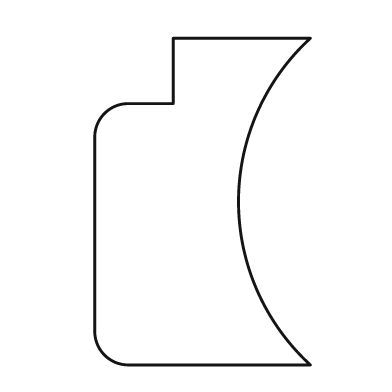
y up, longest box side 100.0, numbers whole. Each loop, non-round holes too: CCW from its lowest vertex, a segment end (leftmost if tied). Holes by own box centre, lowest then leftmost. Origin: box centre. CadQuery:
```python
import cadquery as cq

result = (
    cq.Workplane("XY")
    .moveTo(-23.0, -50.0)
    .lineTo(33.0, -50.0)
    .threePointArc((11.0, 0.0), (33.0, 50.0))
    .lineTo(-9.0, 50.0)
    .lineTo(-9.0, 30.0)
    .lineTo(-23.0, 30.0)
    .threePointArc((-30.0, 27.0), (-33.0, 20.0))
    .lineTo(-33.0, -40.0)
    .threePointArc((-30.0, -47.0), (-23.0, -50.0))
    .close()
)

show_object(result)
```